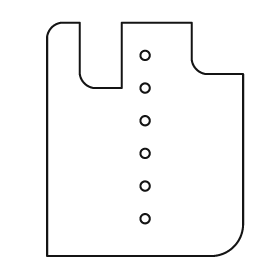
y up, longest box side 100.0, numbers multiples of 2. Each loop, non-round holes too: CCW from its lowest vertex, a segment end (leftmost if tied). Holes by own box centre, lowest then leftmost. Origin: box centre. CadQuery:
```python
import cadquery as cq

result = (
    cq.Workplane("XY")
    .moveTo(-42.0, -50.0)
    .lineTo(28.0, -50.0)
    .threePointArc((38.0, -46.0), (42.0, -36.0))
    .lineTo(42.0, 28.0)
    .lineTo(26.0, 28.0)
    .threePointArc((22.0, 30.0), (20.0, 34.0))
    .lineTo(20.0, 50.0)
    .lineTo(-10.0, 50.0)
    .lineTo(-10.0, 22.0)
    .lineTo(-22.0, 22.0)
    .threePointArc((-26.0, 24.0), (-28.0, 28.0))
    .lineTo(-28.0, 50.0)
    .lineTo(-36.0, 50.0)
    .threePointArc((-40.0, 48.0), (-42.0, 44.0))
    .close()
    .moveTo(0.0, -34.0)
    .circle(2.0)
    .moveTo(0.0, -20.0)
    .circle(2.0)
    .moveTo(0.0, -6.0)
    .circle(2.0)
    .moveTo(0.0, 8.0)
    .circle(2.0)
    .moveTo(0.0, 22.0)
    .circle(2.0)
    .moveTo(0.0, 36.0)
    .circle(2.0)
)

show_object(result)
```